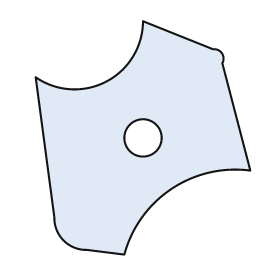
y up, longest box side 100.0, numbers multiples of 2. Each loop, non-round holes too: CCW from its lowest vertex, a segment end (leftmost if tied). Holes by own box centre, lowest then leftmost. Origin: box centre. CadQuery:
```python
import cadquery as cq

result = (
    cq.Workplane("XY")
    .moveTo(-8.0, -50.0)
    .threePointArc((12.0, -22.0), (46.0, -14.0))
    .lineTo(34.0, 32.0)
    .threePointArc((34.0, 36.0), (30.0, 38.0))
    .lineTo(0.0, 50.0)
    .threePointArc((-16.0, 24.0), (-46.0, 26.0))
    .lineTo(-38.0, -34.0)
    .threePointArc((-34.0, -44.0), (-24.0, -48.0))
    .close()
    .moveTo(0.0, 0.0)
    .circle(8.0)
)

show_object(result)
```